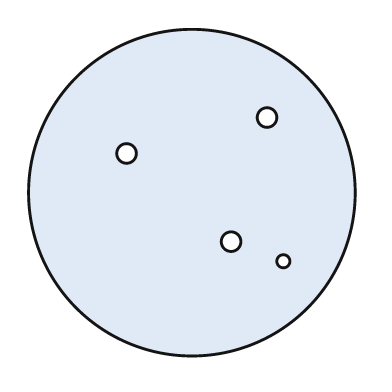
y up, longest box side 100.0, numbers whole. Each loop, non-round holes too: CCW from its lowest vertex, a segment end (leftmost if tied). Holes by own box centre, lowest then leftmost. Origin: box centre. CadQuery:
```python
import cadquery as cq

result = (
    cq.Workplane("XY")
    .moveTo(0.0, 0.0)
    .circle(50.0)
    .moveTo(28.0, -21.0)
    .circle(2.0)
    .moveTo(12.0, -15.0)
    .circle(3.0)
    .moveTo(-20.0, 12.0)
    .circle(3.0)
    .moveTo(23.0, 23.0)
    .circle(3.0)
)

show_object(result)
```